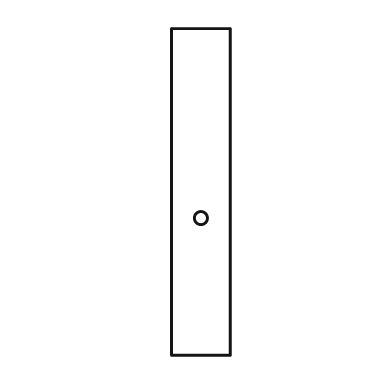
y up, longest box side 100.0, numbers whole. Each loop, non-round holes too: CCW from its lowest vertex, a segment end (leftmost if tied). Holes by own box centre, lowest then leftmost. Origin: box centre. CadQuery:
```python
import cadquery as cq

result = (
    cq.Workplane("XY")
    .moveTo(-9.0, -50.0)
    .lineTo(9.0, -50.0)
    .lineTo(9.0, 50.0)
    .lineTo(-9.0, 50.0)
    .close()
    .moveTo(0.0, -8.0)
    .circle(2.0)
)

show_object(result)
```